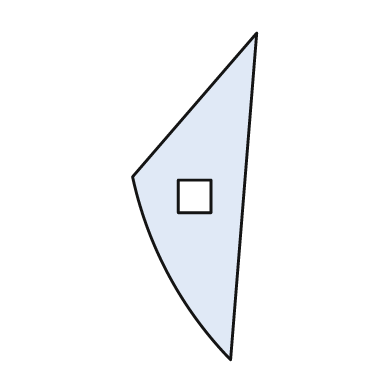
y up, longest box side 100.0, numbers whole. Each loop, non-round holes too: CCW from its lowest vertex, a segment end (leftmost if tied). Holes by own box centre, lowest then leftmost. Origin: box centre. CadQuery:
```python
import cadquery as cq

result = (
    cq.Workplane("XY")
    .moveTo(11.0, -50.0)
    .lineTo(19.0, 50.0)
    .lineTo(-19.0, 6.0)
    .threePointArc((-8.0, -24.0), (11.0, -50.0))
    .close()
    .moveTo(-5.0, -5.0)
    .lineTo(5.0, -5.0)
    .lineTo(5.0, 5.0)
    .lineTo(-5.0, 5.0)
    .close()
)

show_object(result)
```